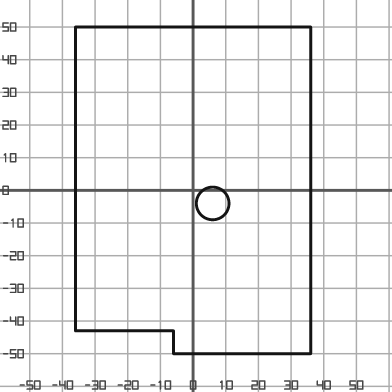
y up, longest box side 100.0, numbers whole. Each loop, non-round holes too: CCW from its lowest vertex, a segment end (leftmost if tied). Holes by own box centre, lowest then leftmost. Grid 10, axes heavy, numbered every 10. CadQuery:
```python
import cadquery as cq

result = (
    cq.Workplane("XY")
    .moveTo(-6.0, -50.0)
    .lineTo(36.0, -50.0)
    .lineTo(36.0, 50.0)
    .lineTo(-36.0, 50.0)
    .lineTo(-36.0, -43.0)
    .lineTo(-6.0, -43.0)
    .close()
    .moveTo(6.0, -4.0)
    .circle(5.0)
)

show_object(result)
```